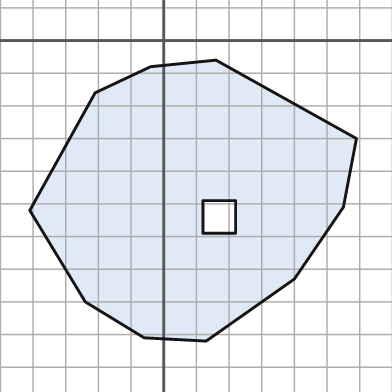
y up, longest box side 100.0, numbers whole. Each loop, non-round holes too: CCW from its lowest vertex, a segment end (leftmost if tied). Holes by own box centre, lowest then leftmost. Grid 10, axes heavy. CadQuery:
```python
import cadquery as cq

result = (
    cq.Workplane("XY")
    .moveTo(13.0, -92.0)
    .lineTo(40.0, -73.0)
    .lineTo(55.0, -51.0)
    .lineTo(59.0, -30.0)
    .lineTo(16.0, -6.0)
    .lineTo(-4.0, -8.0)
    .lineTo(-21.0, -16.0)
    .lineTo(-41.0, -52.0)
    .lineTo(-24.0, -80.0)
    .lineTo(-6.0, -91.0)
    .close()
    .moveTo(12.0, -59.0)
    .lineTo(22.0, -59.0)
    .lineTo(22.0, -49.0)
    .lineTo(12.0, -49.0)
    .close()
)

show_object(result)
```